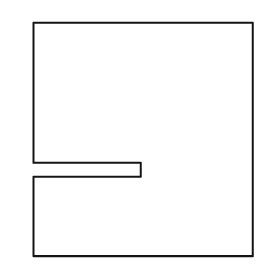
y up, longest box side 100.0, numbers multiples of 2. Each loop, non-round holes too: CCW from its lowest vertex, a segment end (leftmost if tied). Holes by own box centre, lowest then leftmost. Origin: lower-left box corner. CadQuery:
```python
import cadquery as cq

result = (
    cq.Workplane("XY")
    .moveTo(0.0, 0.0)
    .lineTo(94.0, 0.0)
    .lineTo(94.0, 100.0)
    .lineTo(0.0, 100.0)
    .lineTo(0.0, 40.0)
    .lineTo(46.0, 40.0)
    .lineTo(46.0, 34.0)
    .lineTo(0.0, 34.0)
    .close()
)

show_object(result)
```